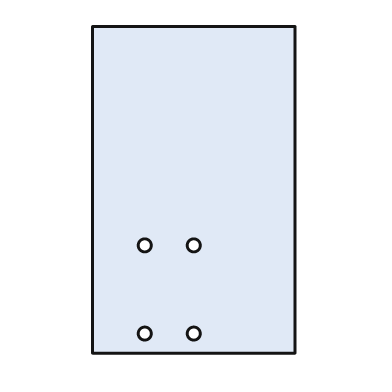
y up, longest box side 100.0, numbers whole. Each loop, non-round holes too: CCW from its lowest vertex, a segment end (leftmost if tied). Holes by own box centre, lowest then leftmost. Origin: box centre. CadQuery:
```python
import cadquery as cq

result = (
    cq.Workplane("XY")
    .moveTo(-31.0, -50.0)
    .lineTo(31.0, -50.0)
    .lineTo(31.0, 50.0)
    .lineTo(-31.0, 50.0)
    .close()
    .moveTo(-15.0, -44.0)
    .circle(2.0)
    .moveTo(0.0, -44.0)
    .circle(2.0)
    .moveTo(-15.0, -17.0)
    .circle(2.0)
    .moveTo(0.0, -17.0)
    .circle(2.0)
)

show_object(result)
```